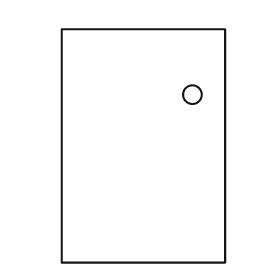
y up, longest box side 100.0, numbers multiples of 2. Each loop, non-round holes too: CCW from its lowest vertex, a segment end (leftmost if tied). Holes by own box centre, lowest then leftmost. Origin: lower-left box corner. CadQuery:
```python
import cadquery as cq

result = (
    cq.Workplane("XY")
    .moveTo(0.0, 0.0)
    .lineTo(70.0, 0.0)
    .lineTo(70.0, 100.0)
    .lineTo(0.0, 100.0)
    .close()
    .moveTo(56.0, 72.0)
    .circle(4.0)
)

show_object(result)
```